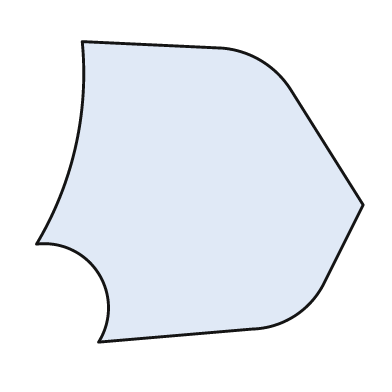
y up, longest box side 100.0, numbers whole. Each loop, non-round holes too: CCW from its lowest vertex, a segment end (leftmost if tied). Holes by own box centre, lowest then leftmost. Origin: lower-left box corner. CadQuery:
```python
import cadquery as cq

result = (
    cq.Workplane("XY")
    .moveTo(19.0, 0.0)
    .lineTo(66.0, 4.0)
    .threePointArc((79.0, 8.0), (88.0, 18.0))
    .lineTo(100.0, 42.0)
    .lineTo(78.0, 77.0)
    .threePointArc((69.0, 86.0), (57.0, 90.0))
    .lineTo(14.0, 92.0)
    .threePointArc((12.0, 60.0), (0.0, 30.0))
    .threePointArc((19.0, 21.0), (19.0, 0.0))
    .close()
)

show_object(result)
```